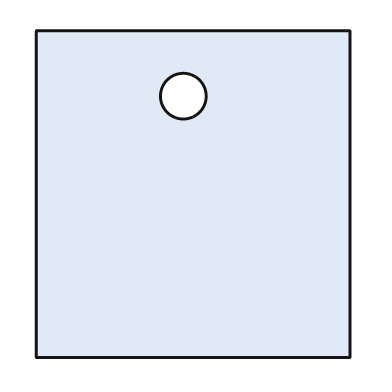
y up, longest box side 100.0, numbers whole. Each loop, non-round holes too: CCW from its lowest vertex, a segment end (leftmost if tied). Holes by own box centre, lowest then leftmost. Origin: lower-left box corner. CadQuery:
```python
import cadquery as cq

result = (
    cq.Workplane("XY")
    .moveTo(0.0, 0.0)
    .lineTo(96.0, 0.0)
    .lineTo(96.0, 100.0)
    .lineTo(0.0, 100.0)
    .close()
    .moveTo(45.0, 80.0)
    .circle(7.0)
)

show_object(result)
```